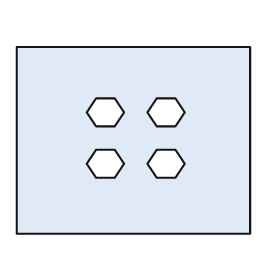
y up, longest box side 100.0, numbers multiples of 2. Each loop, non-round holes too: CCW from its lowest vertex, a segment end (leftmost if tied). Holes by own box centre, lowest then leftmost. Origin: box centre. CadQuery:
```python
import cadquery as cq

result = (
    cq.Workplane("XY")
    .moveTo(-50.0, -40.0)
    .lineTo(50.0, -40.0)
    .lineTo(50.0, 40.0)
    .lineTo(-50.0, 40.0)
    .close()
    .moveTo(-16.0, -16.0)
    .lineTo(-8.0, -16.0)
    .lineTo(-4.0, -10.0)
    .lineTo(-8.0, -4.0)
    .lineTo(-16.0, -4.0)
    .lineTo(-20.0, -10.0)
    .close()
    .moveTo(10.0, -16.0)
    .lineTo(18.0, -16.0)
    .lineTo(22.0, -10.0)
    .lineTo(18.0, -4.0)
    .lineTo(10.0, -4.0)
    .lineTo(6.0, -10.0)
    .close()
    .moveTo(-16.0, 6.0)
    .lineTo(-8.0, 6.0)
    .lineTo(-4.0, 12.0)
    .lineTo(-8.0, 18.0)
    .lineTo(-16.0, 18.0)
    .lineTo(-20.0, 12.0)
    .close()
    .moveTo(10.0, 6.0)
    .lineTo(18.0, 6.0)
    .lineTo(22.0, 12.0)
    .lineTo(18.0, 18.0)
    .lineTo(10.0, 18.0)
    .lineTo(6.0, 12.0)
    .close()
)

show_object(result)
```